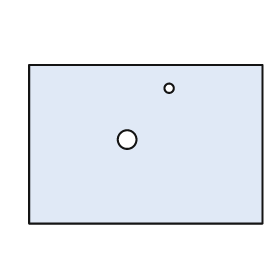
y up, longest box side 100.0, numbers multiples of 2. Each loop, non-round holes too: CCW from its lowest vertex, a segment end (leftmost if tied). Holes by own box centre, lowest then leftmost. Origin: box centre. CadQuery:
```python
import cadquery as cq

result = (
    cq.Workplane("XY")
    .moveTo(-50.0, -34.0)
    .lineTo(50.0, -34.0)
    .lineTo(50.0, 34.0)
    .lineTo(-50.0, 34.0)
    .close()
    .moveTo(-8.0, 2.0)
    .circle(4.0)
    .moveTo(10.0, 24.0)
    .circle(2.0)
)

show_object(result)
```